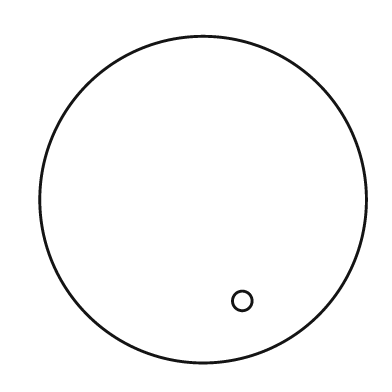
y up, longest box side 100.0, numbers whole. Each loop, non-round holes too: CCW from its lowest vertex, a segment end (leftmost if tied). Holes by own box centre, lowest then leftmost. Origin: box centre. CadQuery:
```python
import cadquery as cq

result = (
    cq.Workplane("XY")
    .moveTo(0.0, 0.0)
    .circle(50.0)
    .moveTo(12.0, -31.0)
    .circle(3.0)
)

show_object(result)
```